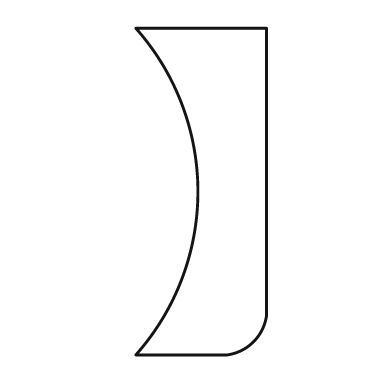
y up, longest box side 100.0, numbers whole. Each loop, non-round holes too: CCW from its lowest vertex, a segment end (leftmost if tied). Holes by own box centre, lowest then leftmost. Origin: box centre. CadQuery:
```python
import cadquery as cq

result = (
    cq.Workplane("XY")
    .moveTo(-20.0, -50.0)
    .lineTo(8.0, -50.0)
    .threePointArc((16.0, -46.0), (20.0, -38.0))
    .lineTo(20.0, 50.0)
    .lineTo(-20.0, 50.0)
    .threePointArc((-1.0, 0.0), (-20.0, -50.0))
    .close()
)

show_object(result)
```